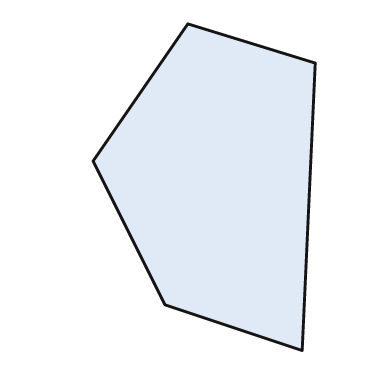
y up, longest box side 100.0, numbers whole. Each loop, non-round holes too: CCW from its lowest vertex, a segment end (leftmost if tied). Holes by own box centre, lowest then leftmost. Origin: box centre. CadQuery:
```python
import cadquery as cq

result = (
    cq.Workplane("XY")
    .moveTo(30.0, -50.0)
    .lineTo(34.0, 38.0)
    .lineTo(-5.0, 50.0)
    .lineTo(-34.0, 8.0)
    .lineTo(-12.0, -36.0)
    .close()
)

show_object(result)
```